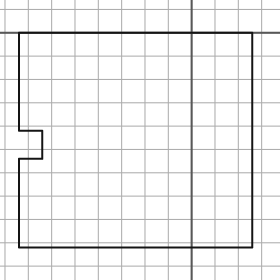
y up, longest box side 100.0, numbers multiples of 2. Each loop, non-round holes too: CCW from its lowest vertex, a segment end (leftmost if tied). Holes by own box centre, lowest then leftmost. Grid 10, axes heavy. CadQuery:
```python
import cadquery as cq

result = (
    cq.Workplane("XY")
    .moveTo(-74.0, -92.0)
    .lineTo(26.0, -92.0)
    .lineTo(26.0, 0.0)
    .lineTo(-74.0, 0.0)
    .lineTo(-74.0, -42.0)
    .lineTo(-64.0, -42.0)
    .lineTo(-64.0, -54.0)
    .lineTo(-74.0, -54.0)
    .close()
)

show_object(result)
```